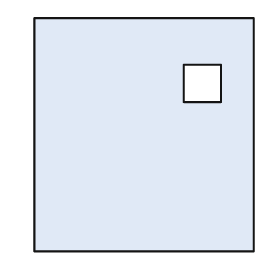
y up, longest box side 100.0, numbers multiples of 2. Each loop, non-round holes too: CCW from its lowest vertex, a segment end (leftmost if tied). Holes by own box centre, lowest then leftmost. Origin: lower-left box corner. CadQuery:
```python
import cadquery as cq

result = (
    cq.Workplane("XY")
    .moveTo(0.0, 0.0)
    .lineTo(94.0, 0.0)
    .lineTo(94.0, 100.0)
    .lineTo(0.0, 100.0)
    .close()
    .moveTo(64.0, 64.0)
    .lineTo(80.0, 64.0)
    .lineTo(80.0, 80.0)
    .lineTo(64.0, 80.0)
    .close()
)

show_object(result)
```